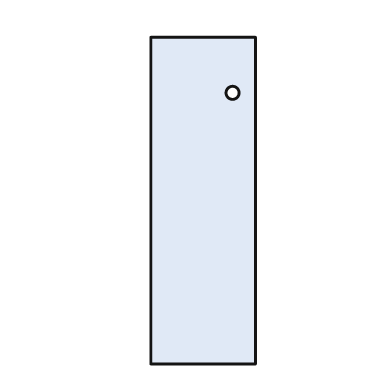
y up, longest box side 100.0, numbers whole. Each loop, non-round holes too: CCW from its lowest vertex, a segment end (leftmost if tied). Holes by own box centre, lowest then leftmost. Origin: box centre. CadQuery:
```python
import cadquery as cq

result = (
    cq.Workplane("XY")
    .moveTo(-16.0, -50.0)
    .lineTo(16.0, -50.0)
    .lineTo(16.0, 50.0)
    .lineTo(-16.0, 50.0)
    .close()
    .moveTo(9.0, 33.0)
    .circle(2.0)
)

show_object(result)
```